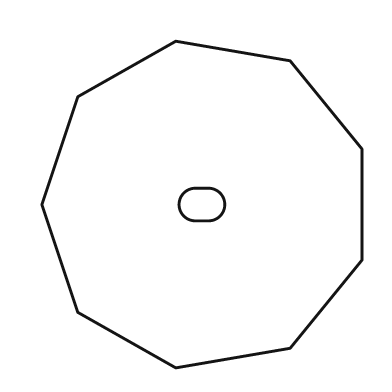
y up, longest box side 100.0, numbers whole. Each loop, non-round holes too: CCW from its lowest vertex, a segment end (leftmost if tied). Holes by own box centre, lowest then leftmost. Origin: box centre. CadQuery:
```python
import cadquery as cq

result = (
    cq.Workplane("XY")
    .moveTo(-8.0, -50.0)
    .lineTo(27.0, -44.0)
    .lineTo(49.0, -17.0)
    .lineTo(49.0, 17.0)
    .lineTo(27.0, 44.0)
    .lineTo(-8.0, 50.0)
    .lineTo(-38.0, 33.0)
    .lineTo(-49.0, 0.0)
    .lineTo(-38.0, -33.0)
    .close()
    .moveTo(-2.0, -5.0)
    .lineTo(2.0, -5.0)
    .threePointArc((7.0, 0.0), (2.0, 5.0))
    .lineTo(-2.0, 5.0)
    .threePointArc((-7.0, 0.0), (-2.0, -5.0))
    .close()
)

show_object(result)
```